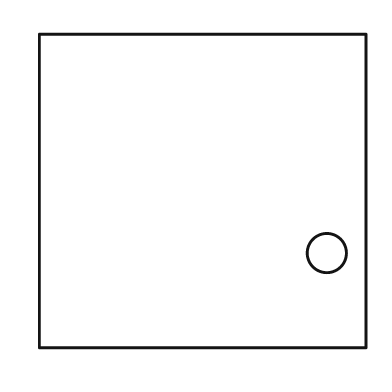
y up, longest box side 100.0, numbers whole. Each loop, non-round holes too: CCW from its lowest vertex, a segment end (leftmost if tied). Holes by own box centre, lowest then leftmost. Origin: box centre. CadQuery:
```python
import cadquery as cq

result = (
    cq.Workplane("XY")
    .moveTo(-50.0, -48.0)
    .lineTo(50.0, -48.0)
    .lineTo(50.0, 48.0)
    .lineTo(-50.0, 48.0)
    .close()
    .moveTo(38.0, -19.0)
    .circle(6.0)
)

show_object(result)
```